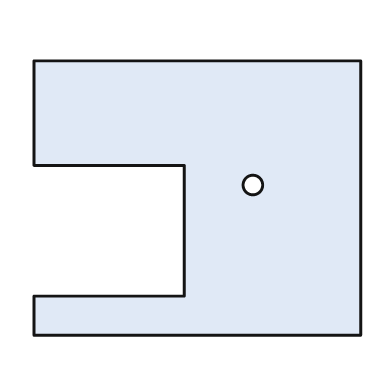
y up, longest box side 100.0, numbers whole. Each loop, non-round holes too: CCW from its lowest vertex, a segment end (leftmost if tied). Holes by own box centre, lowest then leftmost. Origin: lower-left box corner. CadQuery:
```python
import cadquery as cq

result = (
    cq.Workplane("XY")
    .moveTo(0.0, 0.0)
    .lineTo(100.0, 0.0)
    .lineTo(100.0, 84.0)
    .lineTo(0.0, 84.0)
    .lineTo(0.0, 52.0)
    .lineTo(46.0, 52.0)
    .lineTo(46.0, 12.0)
    .lineTo(0.0, 12.0)
    .close()
    .moveTo(67.0, 46.0)
    .circle(3.0)
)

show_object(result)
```